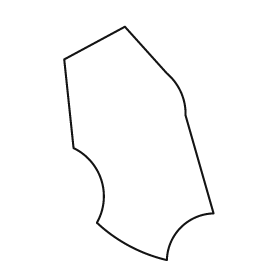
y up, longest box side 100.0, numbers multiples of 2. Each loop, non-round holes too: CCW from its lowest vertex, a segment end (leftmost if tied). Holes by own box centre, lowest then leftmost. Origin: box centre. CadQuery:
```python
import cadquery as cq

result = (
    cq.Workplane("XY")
    .moveTo(12.0, -50.0)
    .threePointArc((18.0, -36.0), (32.0, -30.0))
    .lineTo(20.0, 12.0)
    .threePointArc((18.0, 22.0), (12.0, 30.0))
    .lineTo(-6.0, 50.0)
    .lineTo(-32.0, 36.0)
    .lineTo(-28.0, -2.0)
    .threePointArc((-16.0, -16.0), (-18.0, -34.0))
    .threePointArc((-4.0, -44.0), (12.0, -50.0))
    .close()
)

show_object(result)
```